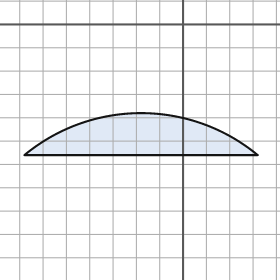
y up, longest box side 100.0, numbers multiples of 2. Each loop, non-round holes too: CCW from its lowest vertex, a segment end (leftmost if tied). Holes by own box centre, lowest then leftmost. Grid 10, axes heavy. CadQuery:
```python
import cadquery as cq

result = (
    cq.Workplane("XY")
    .moveTo(-68.0, -56.0)
    .lineTo(32.0, -56.0)
    .threePointArc((-18.0, -38.0), (-68.0, -56.0))
    .close()
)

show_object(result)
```